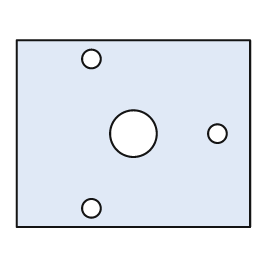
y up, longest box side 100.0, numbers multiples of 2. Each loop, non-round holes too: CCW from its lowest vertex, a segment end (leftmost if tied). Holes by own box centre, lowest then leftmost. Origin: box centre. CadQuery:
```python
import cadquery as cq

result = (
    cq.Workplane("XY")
    .moveTo(-50.0, -40.0)
    .lineTo(50.0, -40.0)
    .lineTo(50.0, 40.0)
    .lineTo(-50.0, 40.0)
    .close()
    .moveTo(-18.0, -32.0)
    .circle(4.0)
    .moveTo(0.0, 0.0)
    .circle(10.0)
    .moveTo(36.0, 0.0)
    .circle(4.0)
    .moveTo(-18.0, 32.0)
    .circle(4.0)
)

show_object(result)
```